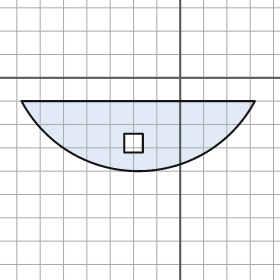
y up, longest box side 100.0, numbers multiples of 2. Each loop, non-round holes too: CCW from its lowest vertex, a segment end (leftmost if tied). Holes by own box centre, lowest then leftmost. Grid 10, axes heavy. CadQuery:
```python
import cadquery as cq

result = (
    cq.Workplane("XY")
    .moveTo(-68.0, -10.0)
    .threePointArc((-18.0, -40.0), (32.0, -10.0))
    .close()
    .moveTo(-24.0, -32.0)
    .lineTo(-16.0, -32.0)
    .lineTo(-16.0, -24.0)
    .lineTo(-24.0, -24.0)
    .close()
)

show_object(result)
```